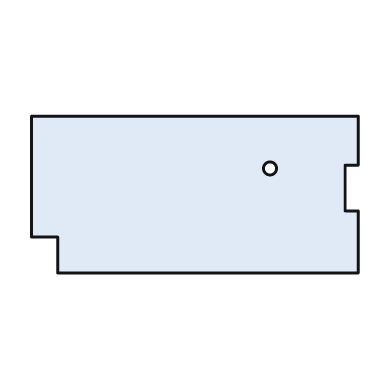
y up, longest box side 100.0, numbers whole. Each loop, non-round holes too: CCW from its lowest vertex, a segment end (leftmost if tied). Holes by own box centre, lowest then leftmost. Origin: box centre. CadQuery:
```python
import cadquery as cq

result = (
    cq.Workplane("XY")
    .moveTo(-42.0, -24.0)
    .lineTo(50.0, -24.0)
    .lineTo(50.0, -5.0)
    .lineTo(46.0, -5.0)
    .lineTo(46.0, 9.0)
    .lineTo(50.0, 9.0)
    .lineTo(50.0, 24.0)
    .lineTo(-50.0, 24.0)
    .lineTo(-50.0, -13.0)
    .lineTo(-42.0, -13.0)
    .close()
    .moveTo(23.0, 8.0)
    .circle(2.0)
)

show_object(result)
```